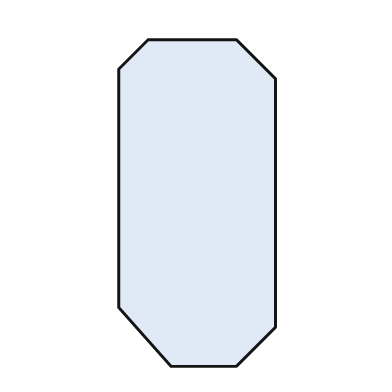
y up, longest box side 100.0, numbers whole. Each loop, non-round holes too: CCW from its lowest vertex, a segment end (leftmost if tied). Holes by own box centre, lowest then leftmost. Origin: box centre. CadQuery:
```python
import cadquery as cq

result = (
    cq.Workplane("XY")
    .moveTo(-8.0, -50.0)
    .lineTo(12.0, -50.0)
    .lineTo(24.0, -38.0)
    .lineTo(24.0, 38.0)
    .lineTo(12.0, 50.0)
    .lineTo(-15.0, 50.0)
    .lineTo(-24.0, 41.0)
    .lineTo(-24.0, -32.0)
    .close()
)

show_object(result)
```